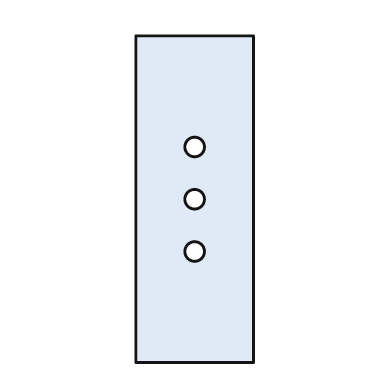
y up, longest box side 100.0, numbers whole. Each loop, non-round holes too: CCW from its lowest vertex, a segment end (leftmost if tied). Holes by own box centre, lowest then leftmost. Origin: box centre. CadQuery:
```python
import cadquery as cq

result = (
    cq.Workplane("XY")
    .moveTo(-18.0, -50.0)
    .lineTo(18.0, -50.0)
    .lineTo(18.0, 50.0)
    .lineTo(-18.0, 50.0)
    .close()
    .moveTo(0.0, -16.0)
    .circle(3.0)
    .moveTo(0.0, 0.0)
    .circle(3.0)
    .moveTo(0.0, 16.0)
    .circle(3.0)
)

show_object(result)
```